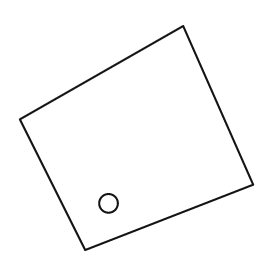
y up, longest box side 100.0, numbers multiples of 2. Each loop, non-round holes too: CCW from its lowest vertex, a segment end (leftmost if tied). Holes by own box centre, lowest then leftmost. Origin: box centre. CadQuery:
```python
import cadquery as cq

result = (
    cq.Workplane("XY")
    .moveTo(-22.0, -48.0)
    .lineTo(50.0, -20.0)
    .lineTo(20.0, 48.0)
    .lineTo(-50.0, 8.0)
    .close()
    .moveTo(-12.0, -28.0)
    .circle(4.0)
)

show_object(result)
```